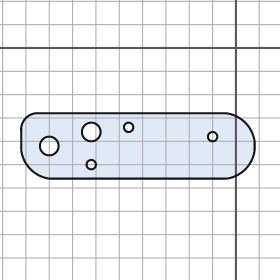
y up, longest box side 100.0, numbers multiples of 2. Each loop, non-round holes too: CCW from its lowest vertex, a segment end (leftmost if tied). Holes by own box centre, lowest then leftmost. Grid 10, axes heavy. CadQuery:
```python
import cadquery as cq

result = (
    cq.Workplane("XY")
    .moveTo(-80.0, -56.0)
    .lineTo(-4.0, -56.0)
    .threePointArc((4.0, -52.0), (8.0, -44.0))
    .lineTo(8.0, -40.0)
    .threePointArc((4.0, -32.0), (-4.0, -28.0))
    .lineTo(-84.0, -28.0)
    .threePointArc((-90.0, -30.0), (-92.0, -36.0))
    .lineTo(-92.0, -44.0)
    .threePointArc((-88.0, -52.0), (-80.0, -56.0))
    .close()
    .moveTo(-62.0, -50.0)
    .circle(2.0)
    .moveTo(-80.0, -42.0)
    .circle(4.0)
    .moveTo(-10.0, -38.0)
    .circle(2.0)
    .moveTo(-62.0, -36.0)
    .circle(4.0)
    .moveTo(-46.0, -34.0)
    .circle(2.0)
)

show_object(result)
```